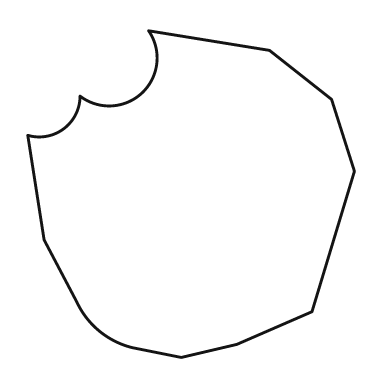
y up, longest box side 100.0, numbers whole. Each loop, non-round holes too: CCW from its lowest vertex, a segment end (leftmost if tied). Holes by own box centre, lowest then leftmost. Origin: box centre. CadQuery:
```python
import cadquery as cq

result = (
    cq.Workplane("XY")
    .moveTo(-3.0, -50.0)
    .lineTo(14.0, -46.0)
    .lineTo(37.0, -36.0)
    .lineTo(50.0, 7.0)
    .lineTo(43.0, 29.0)
    .lineTo(24.0, 44.0)
    .lineTo(-13.0, 50.0)
    .threePointArc((-15.0, 31.0), (-34.0, 30.0))
    .threePointArc((-39.0, 20.0), (-50.0, 18.0))
    .lineTo(-45.0, -14.0)
    .lineTo(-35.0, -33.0)
    .threePointArc((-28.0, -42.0), (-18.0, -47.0))
    .close()
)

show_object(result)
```